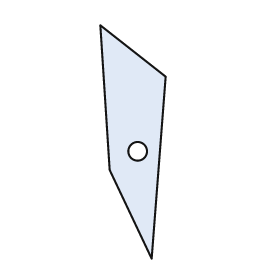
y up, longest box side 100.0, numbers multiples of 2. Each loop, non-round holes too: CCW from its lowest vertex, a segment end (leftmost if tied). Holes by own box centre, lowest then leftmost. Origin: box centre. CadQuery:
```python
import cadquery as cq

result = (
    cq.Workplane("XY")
    .moveTo(8.0, -50.0)
    .lineTo(14.0, 28.0)
    .lineTo(-14.0, 50.0)
    .lineTo(-10.0, -12.0)
    .close()
    .moveTo(2.0, -4.0)
    .circle(4.0)
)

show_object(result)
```